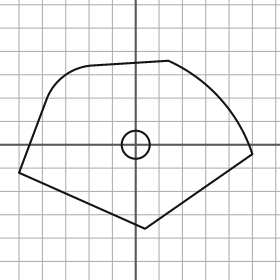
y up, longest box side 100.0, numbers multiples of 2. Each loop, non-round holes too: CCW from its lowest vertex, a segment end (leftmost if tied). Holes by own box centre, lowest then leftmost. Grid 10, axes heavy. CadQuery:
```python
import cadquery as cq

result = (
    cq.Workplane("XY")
    .moveTo(4.0, -36.0)
    .lineTo(50.0, -4.0)
    .threePointArc((36.0, 20.0), (14.0, 36.0))
    .lineTo(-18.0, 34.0)
    .threePointArc((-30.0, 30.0), (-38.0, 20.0))
    .lineTo(-50.0, -12.0)
    .close()
    .moveTo(0.0, 0.0)
    .circle(6.0)
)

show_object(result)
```